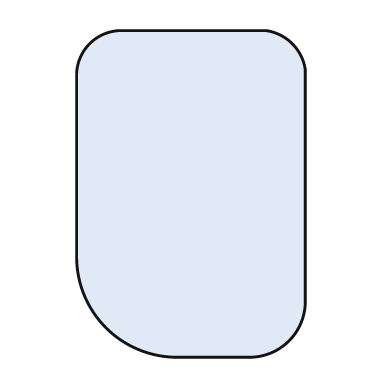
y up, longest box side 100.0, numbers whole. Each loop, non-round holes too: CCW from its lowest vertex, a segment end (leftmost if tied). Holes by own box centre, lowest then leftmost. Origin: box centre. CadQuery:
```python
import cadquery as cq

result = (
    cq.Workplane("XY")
    .moveTo(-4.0, -50.0)
    .lineTo(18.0, -50.0)
    .threePointArc((30.0, -45.0), (35.0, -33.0))
    .lineTo(35.0, 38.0)
    .threePointArc((31.0, 46.0), (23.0, 50.0))
    .lineTo(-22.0, 50.0)
    .threePointArc((-31.0, 46.0), (-35.0, 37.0))
    .lineTo(-35.0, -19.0)
    .threePointArc((-26.0, -41.0), (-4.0, -50.0))
    .close()
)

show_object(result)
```